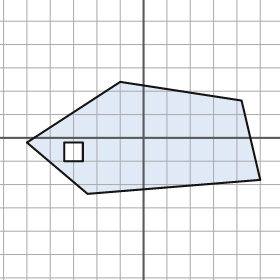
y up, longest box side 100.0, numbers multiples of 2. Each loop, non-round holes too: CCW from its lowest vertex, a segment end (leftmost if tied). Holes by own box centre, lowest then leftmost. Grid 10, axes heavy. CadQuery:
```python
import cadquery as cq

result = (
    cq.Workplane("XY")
    .moveTo(-24.0, -24.0)
    .lineTo(50.0, -18.0)
    .lineTo(42.0, 16.0)
    .lineTo(-10.0, 24.0)
    .lineTo(-50.0, -2.0)
    .close()
    .moveTo(-34.0, -10.0)
    .lineTo(-26.0, -10.0)
    .lineTo(-26.0, -2.0)
    .lineTo(-34.0, -2.0)
    .close()
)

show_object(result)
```